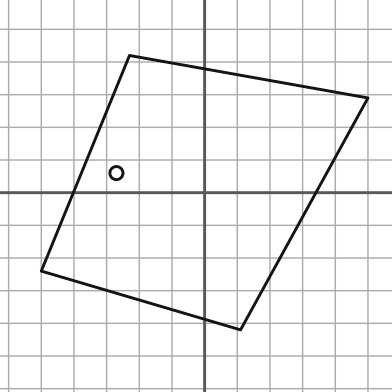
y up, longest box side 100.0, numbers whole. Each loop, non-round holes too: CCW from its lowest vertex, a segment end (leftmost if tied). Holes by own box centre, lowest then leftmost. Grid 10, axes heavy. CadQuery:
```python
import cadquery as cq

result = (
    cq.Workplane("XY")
    .moveTo(11.0, -42.0)
    .lineTo(50.0, 29.0)
    .lineTo(-23.0, 42.0)
    .lineTo(-50.0, -24.0)
    .close()
    .moveTo(-27.0, 6.0)
    .circle(2.0)
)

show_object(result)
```